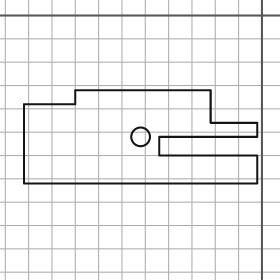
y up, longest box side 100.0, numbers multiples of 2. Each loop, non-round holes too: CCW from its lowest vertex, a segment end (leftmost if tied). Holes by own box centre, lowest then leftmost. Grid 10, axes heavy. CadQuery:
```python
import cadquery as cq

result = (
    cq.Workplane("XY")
    .moveTo(-102.0, -72.0)
    .lineTo(-2.0, -72.0)
    .lineTo(-2.0, -60.0)
    .lineTo(-44.0, -60.0)
    .lineTo(-44.0, -52.0)
    .lineTo(-2.0, -52.0)
    .lineTo(-2.0, -46.0)
    .lineTo(-22.0, -46.0)
    .lineTo(-22.0, -32.0)
    .lineTo(-80.0, -32.0)
    .lineTo(-80.0, -38.0)
    .lineTo(-102.0, -38.0)
    .close()
    .moveTo(-52.0, -52.0)
    .circle(4.0)
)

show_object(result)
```